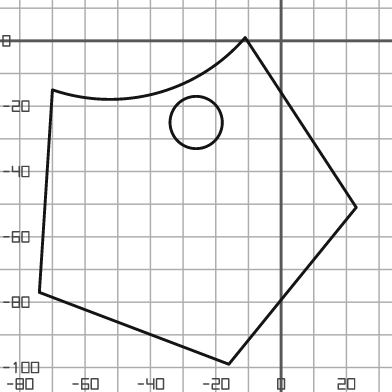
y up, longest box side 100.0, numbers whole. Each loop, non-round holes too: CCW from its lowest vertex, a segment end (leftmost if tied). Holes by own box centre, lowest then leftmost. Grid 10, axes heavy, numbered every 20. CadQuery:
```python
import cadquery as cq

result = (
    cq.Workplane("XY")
    .moveTo(-16.0, -99.0)
    .lineTo(23.0, -51.0)
    .lineTo(-11.0, 1.0)
    .threePointArc((-38.0, -16.0), (-70.0, -15.0))
    .lineTo(-74.0, -77.0)
    .close()
    .moveTo(-26.0, -25.0)
    .circle(8.0)
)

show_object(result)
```